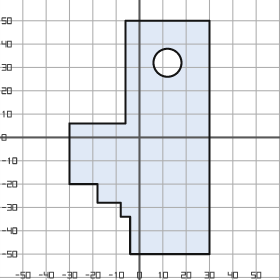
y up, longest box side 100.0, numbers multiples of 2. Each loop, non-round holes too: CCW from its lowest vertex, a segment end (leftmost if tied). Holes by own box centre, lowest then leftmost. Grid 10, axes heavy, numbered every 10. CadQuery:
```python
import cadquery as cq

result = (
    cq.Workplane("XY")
    .moveTo(-4.0, -50.0)
    .lineTo(30.0, -50.0)
    .lineTo(30.0, 50.0)
    .lineTo(-6.0, 50.0)
    .lineTo(-6.0, 6.0)
    .lineTo(-30.0, 6.0)
    .lineTo(-30.0, -20.0)
    .lineTo(-18.0, -20.0)
    .lineTo(-18.0, -28.0)
    .lineTo(-8.0, -28.0)
    .lineTo(-8.0, -34.0)
    .lineTo(-4.0, -34.0)
    .close()
    .moveTo(12.0, 32.0)
    .circle(6.0)
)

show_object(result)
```